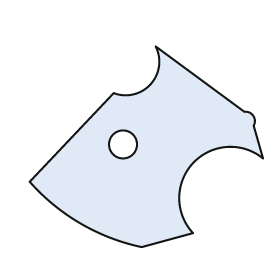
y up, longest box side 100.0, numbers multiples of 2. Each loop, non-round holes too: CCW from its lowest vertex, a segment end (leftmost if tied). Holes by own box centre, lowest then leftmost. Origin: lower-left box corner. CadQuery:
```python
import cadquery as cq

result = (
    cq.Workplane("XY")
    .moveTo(48.0, 0.0)
    .lineTo(70.0, 6.0)
    .threePointArc((70.0, 36.0), (100.0, 38.0))
    .lineTo(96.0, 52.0)
    .threePointArc((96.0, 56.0), (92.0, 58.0))
    .lineTo(54.0, 86.0)
    .threePointArc((52.0, 70.0), (36.0, 66.0))
    .lineTo(0.0, 28.0)
    .threePointArc((22.0, 10.0), (48.0, 0.0))
    .close()
    .moveTo(40.0, 44.0)
    .circle(6.0)
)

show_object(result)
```